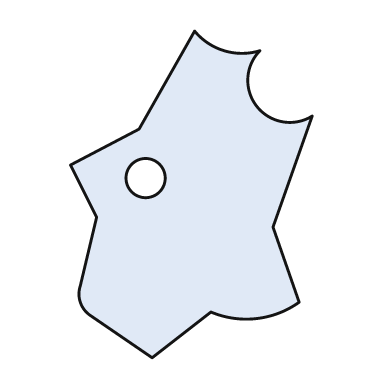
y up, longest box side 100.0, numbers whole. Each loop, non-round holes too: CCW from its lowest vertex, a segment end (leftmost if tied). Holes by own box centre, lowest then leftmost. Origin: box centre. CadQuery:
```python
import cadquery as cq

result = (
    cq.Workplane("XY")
    .moveTo(-12.0, -50.0)
    .lineTo(6.0, -36.0)
    .threePointArc((20.0, -38.0), (33.0, -33.0))
    .lineTo(25.0, -10.0)
    .lineTo(37.0, 24.0)
    .threePointArc((20.0, 27.0), (21.0, 44.0))
    .threePointArc((10.0, 44.0), (1.0, 50.0))
    .lineTo(-16.0, 20.0)
    .lineTo(-37.0, 9.0)
    .lineTo(-29.0, -7.0)
    .lineTo(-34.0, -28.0)
    .threePointArc((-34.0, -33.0), (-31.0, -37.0))
    .close()
    .moveTo(-14.0, 5.0)
    .circle(6.0)
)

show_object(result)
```